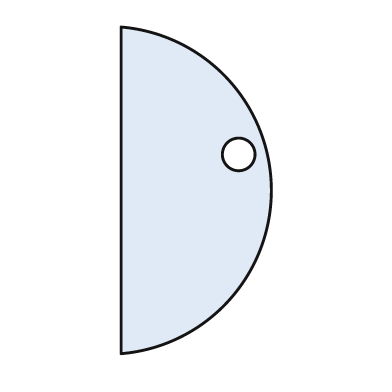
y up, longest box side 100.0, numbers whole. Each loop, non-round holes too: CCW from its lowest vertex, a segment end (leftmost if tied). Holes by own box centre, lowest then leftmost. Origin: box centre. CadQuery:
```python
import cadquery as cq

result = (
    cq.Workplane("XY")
    .moveTo(-23.0, -50.0)
    .threePointArc((23.0, 0.0), (-23.0, 50.0))
    .close()
    .moveTo(13.0, 11.0)
    .circle(5.0)
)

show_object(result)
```